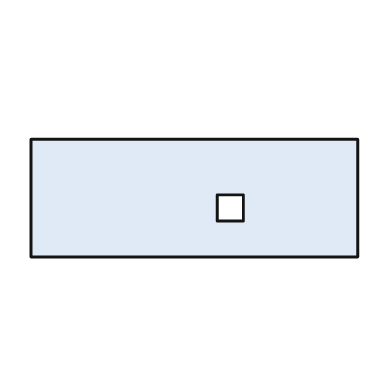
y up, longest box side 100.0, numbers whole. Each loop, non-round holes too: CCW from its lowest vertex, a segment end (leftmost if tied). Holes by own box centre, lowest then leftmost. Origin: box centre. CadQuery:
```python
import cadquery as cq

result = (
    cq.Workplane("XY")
    .moveTo(-50.0, -18.0)
    .lineTo(50.0, -18.0)
    .lineTo(50.0, 18.0)
    .lineTo(-50.0, 18.0)
    .close()
    .moveTo(7.0, -7.0)
    .lineTo(15.0, -7.0)
    .lineTo(15.0, 1.0)
    .lineTo(7.0, 1.0)
    .close()
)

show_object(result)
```